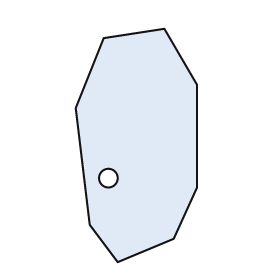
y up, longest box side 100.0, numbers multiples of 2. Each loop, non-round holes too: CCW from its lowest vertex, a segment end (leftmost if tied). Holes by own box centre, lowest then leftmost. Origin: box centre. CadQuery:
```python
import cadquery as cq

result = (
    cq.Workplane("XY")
    .moveTo(-8.0, -50.0)
    .lineTo(16.0, -40.0)
    .lineTo(26.0, -18.0)
    .lineTo(26.0, 26.0)
    .lineTo(12.0, 50.0)
    .lineTo(-14.0, 46.0)
    .lineTo(-26.0, 16.0)
    .lineTo(-20.0, -34.0)
    .close()
    .moveTo(-12.0, -14.0)
    .circle(4.0)
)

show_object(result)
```